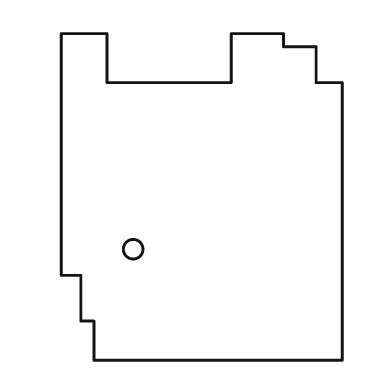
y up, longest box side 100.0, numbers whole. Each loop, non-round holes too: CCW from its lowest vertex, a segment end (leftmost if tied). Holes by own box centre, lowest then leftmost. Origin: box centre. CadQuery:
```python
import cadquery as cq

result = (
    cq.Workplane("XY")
    .moveTo(-33.0, -50.0)
    .lineTo(43.0, -50.0)
    .lineTo(43.0, 35.0)
    .lineTo(35.0, 35.0)
    .lineTo(35.0, 46.0)
    .lineTo(25.0, 46.0)
    .lineTo(25.0, 50.0)
    .lineTo(9.0, 50.0)
    .lineTo(9.0, 35.0)
    .lineTo(-29.0, 35.0)
    .lineTo(-29.0, 50.0)
    .lineTo(-43.0, 50.0)
    .lineTo(-43.0, -24.0)
    .lineTo(-37.0, -24.0)
    .lineTo(-37.0, -38.0)
    .lineTo(-33.0, -38.0)
    .close()
    .moveTo(-21.0, -16.0)
    .circle(3.0)
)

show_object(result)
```